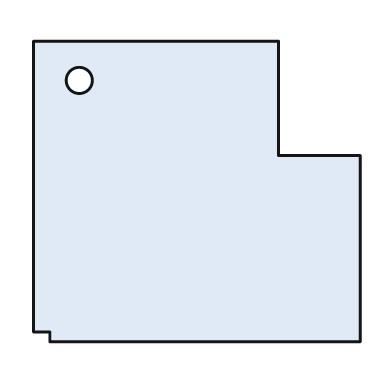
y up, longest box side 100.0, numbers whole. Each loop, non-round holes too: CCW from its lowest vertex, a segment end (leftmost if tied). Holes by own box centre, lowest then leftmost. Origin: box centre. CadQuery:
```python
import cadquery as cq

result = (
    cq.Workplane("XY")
    .moveTo(-45.0, -46.0)
    .lineTo(50.0, -46.0)
    .lineTo(50.0, 11.0)
    .lineTo(25.0, 11.0)
    .lineTo(25.0, 46.0)
    .lineTo(-50.0, 46.0)
    .lineTo(-50.0, -43.0)
    .lineTo(-45.0, -43.0)
    .close()
    .moveTo(-36.0, 34.0)
    .circle(4.0)
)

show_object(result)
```